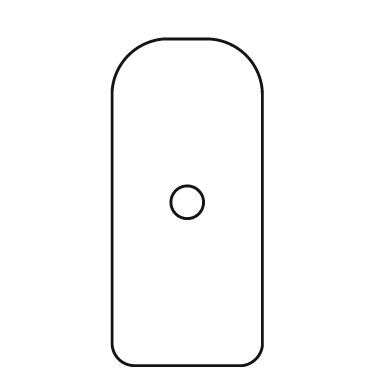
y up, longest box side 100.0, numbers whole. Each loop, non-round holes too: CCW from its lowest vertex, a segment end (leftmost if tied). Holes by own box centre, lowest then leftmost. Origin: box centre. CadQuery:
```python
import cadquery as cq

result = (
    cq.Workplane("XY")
    .moveTo(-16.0, -50.0)
    .lineTo(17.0, -50.0)
    .threePointArc((21.0, -48.0), (23.0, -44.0))
    .lineTo(23.0, 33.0)
    .threePointArc((18.0, 45.0), (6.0, 50.0))
    .lineTo(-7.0, 50.0)
    .threePointArc((-18.0, 45.0), (-23.0, 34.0))
    .lineTo(-23.0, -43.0)
    .threePointArc((-21.0, -48.0), (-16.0, -50.0))
    .close()
    .moveTo(0.0, 0.0)
    .circle(5.0)
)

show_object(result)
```